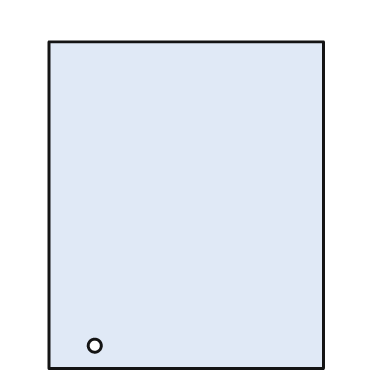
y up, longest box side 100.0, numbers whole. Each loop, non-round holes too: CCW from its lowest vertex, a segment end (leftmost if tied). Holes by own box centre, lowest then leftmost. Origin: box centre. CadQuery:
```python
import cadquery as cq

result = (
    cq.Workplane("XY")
    .moveTo(-42.0, -50.0)
    .lineTo(42.0, -50.0)
    .lineTo(42.0, 50.0)
    .lineTo(-42.0, 50.0)
    .close()
    .moveTo(-28.0, -43.0)
    .circle(2.0)
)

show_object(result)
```